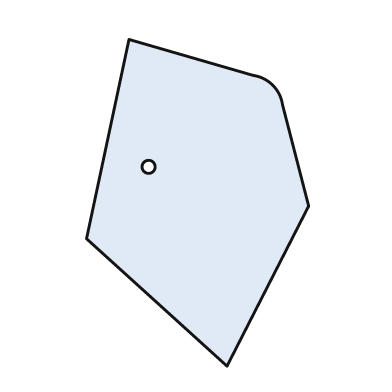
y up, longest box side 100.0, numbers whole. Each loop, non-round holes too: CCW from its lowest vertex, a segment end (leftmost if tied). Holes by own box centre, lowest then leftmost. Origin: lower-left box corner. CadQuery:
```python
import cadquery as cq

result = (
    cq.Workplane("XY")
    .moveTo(43.0, 0.0)
    .lineTo(68.0, 49.0)
    .lineTo(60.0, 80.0)
    .threePointArc((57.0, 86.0), (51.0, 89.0))
    .lineTo(13.0, 100.0)
    .lineTo(0.0, 39.0)
    .close()
    .moveTo(19.0, 61.0)
    .circle(2.0)
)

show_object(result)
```